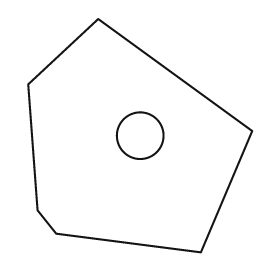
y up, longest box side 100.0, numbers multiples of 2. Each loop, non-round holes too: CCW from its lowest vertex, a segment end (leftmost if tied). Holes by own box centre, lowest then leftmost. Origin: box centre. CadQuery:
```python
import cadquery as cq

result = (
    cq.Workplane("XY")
    .moveTo(26.0, -50.0)
    .lineTo(48.0, 2.0)
    .lineTo(-18.0, 50.0)
    .lineTo(-48.0, 22.0)
    .lineTo(-44.0, -32.0)
    .lineTo(-36.0, -42.0)
    .close()
    .moveTo(0.0, 0.0)
    .circle(10.0)
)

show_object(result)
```